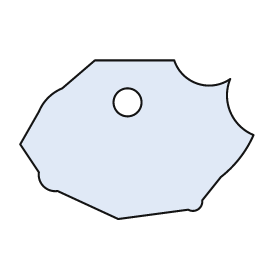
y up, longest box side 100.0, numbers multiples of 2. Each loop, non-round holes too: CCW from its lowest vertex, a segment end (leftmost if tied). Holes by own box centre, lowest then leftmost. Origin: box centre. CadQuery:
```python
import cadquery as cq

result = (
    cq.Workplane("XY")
    .moveTo(-8.0, -34.0)
    .lineTo(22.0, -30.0)
    .threePointArc((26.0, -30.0), (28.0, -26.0))
    .lineTo(36.0, -16.0)
    .threePointArc((44.0, -8.0), (50.0, 2.0))
    .threePointArc((40.0, 12.0), (40.0, 26.0))
    .threePointArc((26.0, 24.0), (16.0, 34.0))
    .lineTo(-18.0, 34.0)
    .lineTo(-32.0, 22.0)
    .threePointArc((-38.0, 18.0), (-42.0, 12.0))
    .lineTo(-50.0, -2.0)
    .lineTo(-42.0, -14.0)
    .threePointArc((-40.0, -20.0), (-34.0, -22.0))
    .close()
    .moveTo(-4.0, 16.0)
    .circle(6.0)
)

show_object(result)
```